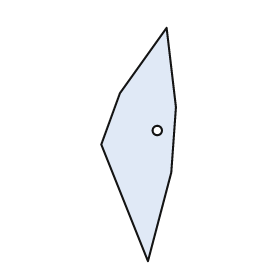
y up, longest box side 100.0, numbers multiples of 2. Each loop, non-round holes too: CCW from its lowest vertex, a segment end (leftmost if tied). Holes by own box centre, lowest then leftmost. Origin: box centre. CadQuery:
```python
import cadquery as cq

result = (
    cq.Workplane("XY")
    .moveTo(4.0, -50.0)
    .lineTo(14.0, -12.0)
    .lineTo(16.0, 16.0)
    .lineTo(12.0, 50.0)
    .lineTo(-8.0, 22.0)
    .lineTo(-16.0, 0.0)
    .close()
    .moveTo(8.0, 6.0)
    .circle(2.0)
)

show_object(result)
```